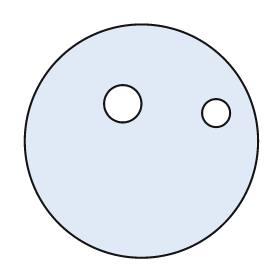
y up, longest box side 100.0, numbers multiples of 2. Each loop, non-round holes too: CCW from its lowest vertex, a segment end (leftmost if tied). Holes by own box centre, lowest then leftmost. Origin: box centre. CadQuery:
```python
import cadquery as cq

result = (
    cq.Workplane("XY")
    .moveTo(0.0, 0.0)
    .circle(50.0)
    .moveTo(32.0, 12.0)
    .circle(6.0)
    .moveTo(-8.0, 16.0)
    .circle(8.0)
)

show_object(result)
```